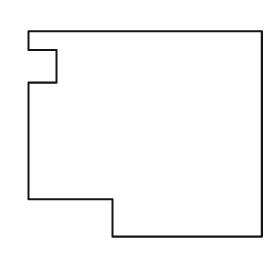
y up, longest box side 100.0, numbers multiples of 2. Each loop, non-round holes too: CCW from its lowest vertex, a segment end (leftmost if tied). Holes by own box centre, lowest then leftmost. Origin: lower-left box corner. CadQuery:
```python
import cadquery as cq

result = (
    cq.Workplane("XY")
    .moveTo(36.0, 0.0)
    .lineTo(100.0, 0.0)
    .lineTo(100.0, 88.0)
    .lineTo(0.0, 88.0)
    .lineTo(0.0, 80.0)
    .lineTo(12.0, 80.0)
    .lineTo(12.0, 66.0)
    .lineTo(0.0, 66.0)
    .lineTo(0.0, 16.0)
    .lineTo(36.0, 16.0)
    .close()
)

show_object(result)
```